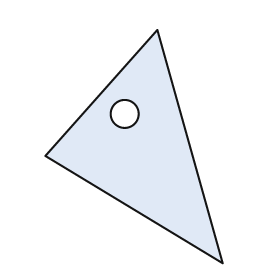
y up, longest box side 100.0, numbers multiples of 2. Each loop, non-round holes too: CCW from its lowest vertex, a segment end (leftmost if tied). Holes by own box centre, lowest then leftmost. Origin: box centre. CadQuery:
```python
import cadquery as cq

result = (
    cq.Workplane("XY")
    .moveTo(38.0, -50.0)
    .lineTo(10.0, 50.0)
    .lineTo(-38.0, -4.0)
    .close()
    .moveTo(-4.0, 14.0)
    .circle(6.0)
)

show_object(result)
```